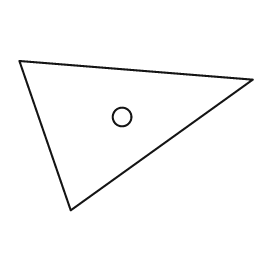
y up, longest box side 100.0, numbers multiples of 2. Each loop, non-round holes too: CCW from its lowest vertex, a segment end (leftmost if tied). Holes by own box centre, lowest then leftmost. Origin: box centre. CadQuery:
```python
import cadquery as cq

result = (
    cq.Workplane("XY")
    .moveTo(-28.0, -32.0)
    .lineTo(50.0, 24.0)
    .lineTo(-50.0, 32.0)
    .close()
    .moveTo(-6.0, 8.0)
    .circle(4.0)
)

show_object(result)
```